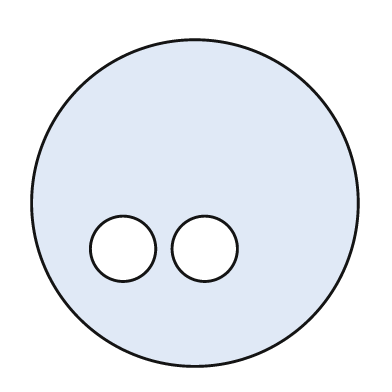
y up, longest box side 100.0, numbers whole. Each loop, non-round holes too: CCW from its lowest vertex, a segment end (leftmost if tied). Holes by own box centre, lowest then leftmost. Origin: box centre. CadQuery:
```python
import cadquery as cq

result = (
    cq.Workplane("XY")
    .moveTo(0.0, 0.0)
    .circle(50.0)
    .moveTo(-22.0, -14.0)
    .circle(10.0)
    .moveTo(3.0, -14.0)
    .circle(10.0)
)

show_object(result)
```